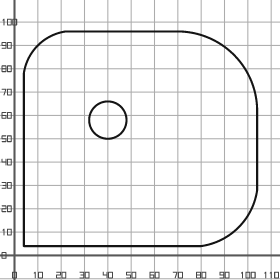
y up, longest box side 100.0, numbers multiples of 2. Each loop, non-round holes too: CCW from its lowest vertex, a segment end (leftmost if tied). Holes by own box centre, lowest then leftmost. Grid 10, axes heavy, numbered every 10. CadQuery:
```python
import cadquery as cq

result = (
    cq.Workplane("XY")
    .moveTo(4.0, 4.0)
    .lineTo(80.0, 4.0)
    .threePointArc((96.0, 12.0), (104.0, 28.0))
    .lineTo(104.0, 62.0)
    .threePointArc((94.0, 86.0), (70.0, 96.0))
    .lineTo(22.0, 96.0)
    .threePointArc((10.0, 90.0), (4.0, 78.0))
    .close()
    .moveTo(40.0, 58.0)
    .circle(8.0)
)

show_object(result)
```